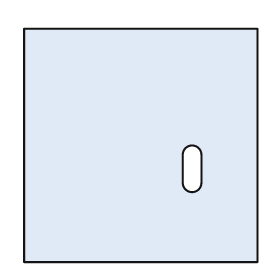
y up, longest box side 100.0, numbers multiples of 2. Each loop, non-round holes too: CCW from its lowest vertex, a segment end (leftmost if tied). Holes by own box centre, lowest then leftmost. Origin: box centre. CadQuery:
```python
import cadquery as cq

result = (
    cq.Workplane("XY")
    .moveTo(-50.0, -50.0)
    .lineTo(50.0, -50.0)
    .lineTo(50.0, 50.0)
    .lineTo(-50.0, 50.0)
    .close()
    .moveTo(18.0, -16.0)
    .threePointArc((22.0, -20.0), (26.0, -16.0))
    .lineTo(26.0, -4.0)
    .threePointArc((22.0, 0.0), (18.0, -4.0))
    .close()
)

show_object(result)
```